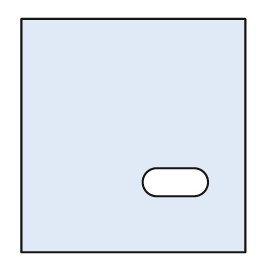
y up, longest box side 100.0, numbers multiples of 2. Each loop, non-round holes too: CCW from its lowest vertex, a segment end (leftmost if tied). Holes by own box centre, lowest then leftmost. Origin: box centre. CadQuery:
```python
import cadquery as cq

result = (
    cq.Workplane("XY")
    .moveTo(-48.0, -50.0)
    .lineTo(48.0, -50.0)
    .lineTo(48.0, 50.0)
    .lineTo(-48.0, 50.0)
    .close()
    .moveTo(10.0, -26.0)
    .lineTo(26.0, -26.0)
    .threePointArc((32.0, -20.0), (26.0, -14.0))
    .lineTo(10.0, -14.0)
    .threePointArc((4.0, -20.0), (10.0, -26.0))
    .close()
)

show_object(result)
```